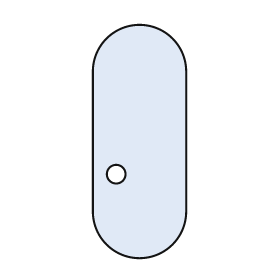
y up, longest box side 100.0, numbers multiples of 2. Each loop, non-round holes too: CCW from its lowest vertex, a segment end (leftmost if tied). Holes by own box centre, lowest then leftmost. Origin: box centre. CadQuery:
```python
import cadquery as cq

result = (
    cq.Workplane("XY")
    .moveTo(-20.0, -30.0)
    .threePointArc((0.0, -50.0), (20.0, -30.0))
    .lineTo(20.0, 30.0)
    .threePointArc((0.0, 50.0), (-20.0, 30.0))
    .close()
    .moveTo(-10.0, -14.0)
    .circle(4.0)
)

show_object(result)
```